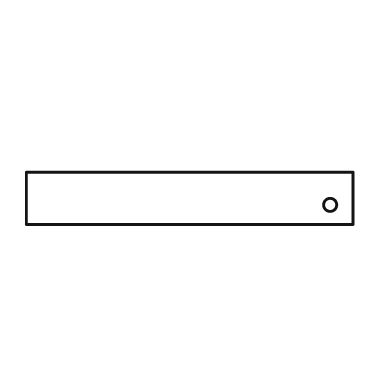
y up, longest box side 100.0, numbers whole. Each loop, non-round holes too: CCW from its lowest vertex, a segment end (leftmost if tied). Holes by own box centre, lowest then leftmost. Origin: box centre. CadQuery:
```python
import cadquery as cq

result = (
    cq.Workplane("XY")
    .moveTo(-50.0, -8.0)
    .lineTo(50.0, -8.0)
    .lineTo(50.0, 8.0)
    .lineTo(-50.0, 8.0)
    .close()
    .moveTo(43.0, -2.0)
    .circle(2.0)
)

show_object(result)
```